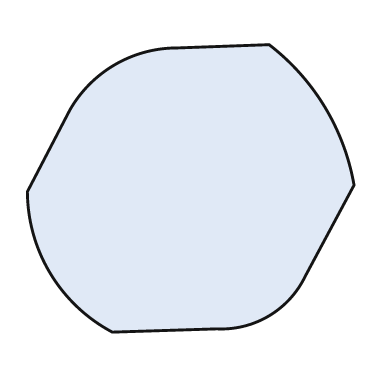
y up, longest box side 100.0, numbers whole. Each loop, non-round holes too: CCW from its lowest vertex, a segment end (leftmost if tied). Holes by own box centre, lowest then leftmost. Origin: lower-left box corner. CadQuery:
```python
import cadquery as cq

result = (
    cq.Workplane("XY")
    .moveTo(26.0, 0.0)
    .lineTo(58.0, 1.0)
    .threePointArc((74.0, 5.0), (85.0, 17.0))
    .lineTo(100.0, 45.0)
    .threePointArc((91.0, 69.0), (74.0, 88.0))
    .lineTo(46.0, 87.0)
    .threePointArc((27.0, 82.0), (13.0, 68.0))
    .lineTo(0.0, 43.0)
    .threePointArc((7.0, 18.0), (26.0, 0.0))
    .close()
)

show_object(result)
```